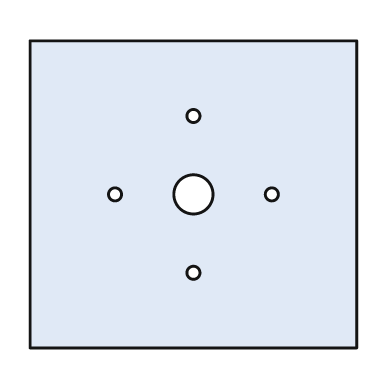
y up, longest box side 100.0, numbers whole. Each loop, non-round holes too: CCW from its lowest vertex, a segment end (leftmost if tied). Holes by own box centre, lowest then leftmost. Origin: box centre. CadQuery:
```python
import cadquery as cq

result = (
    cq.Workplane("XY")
    .moveTo(-50.0, -47.0)
    .lineTo(50.0, -47.0)
    .lineTo(50.0, 47.0)
    .lineTo(-50.0, 47.0)
    .close()
    .moveTo(0.0, -24.0)
    .circle(2.0)
    .moveTo(-24.0, 0.0)
    .circle(2.0)
    .moveTo(0.0, 0.0)
    .circle(6.0)
    .moveTo(24.0, 0.0)
    .circle(2.0)
    .moveTo(0.0, 24.0)
    .circle(2.0)
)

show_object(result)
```